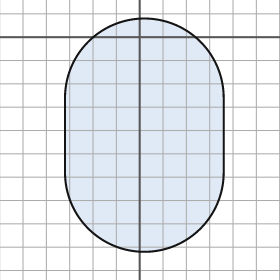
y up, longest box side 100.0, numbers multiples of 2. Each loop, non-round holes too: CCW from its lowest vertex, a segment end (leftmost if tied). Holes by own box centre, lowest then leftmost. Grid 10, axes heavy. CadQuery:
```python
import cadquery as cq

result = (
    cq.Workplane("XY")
    .moveTo(-32.0, -58.0)
    .threePointArc((2.0, -92.0), (36.0, -58.0))
    .lineTo(36.0, -26.0)
    .threePointArc((2.0, 8.0), (-32.0, -26.0))
    .close()
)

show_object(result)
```